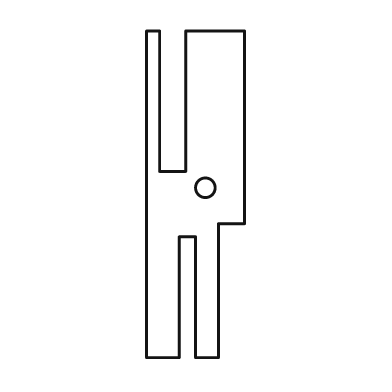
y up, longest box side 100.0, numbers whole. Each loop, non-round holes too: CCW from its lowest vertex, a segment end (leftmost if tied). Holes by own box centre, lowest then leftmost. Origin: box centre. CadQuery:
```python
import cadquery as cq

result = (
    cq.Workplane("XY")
    .moveTo(-15.0, -50.0)
    .lineTo(-5.0, -50.0)
    .lineTo(-5.0, -13.0)
    .lineTo(0.0, -13.0)
    .lineTo(0.0, -50.0)
    .lineTo(7.0, -50.0)
    .lineTo(7.0, -9.0)
    .lineTo(15.0, -9.0)
    .lineTo(15.0, 50.0)
    .lineTo(-3.0, 50.0)
    .lineTo(-3.0, 7.0)
    .lineTo(-11.0, 7.0)
    .lineTo(-11.0, 50.0)
    .lineTo(-15.0, 50.0)
    .close()
    .moveTo(3.0, 2.0)
    .circle(3.0)
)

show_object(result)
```